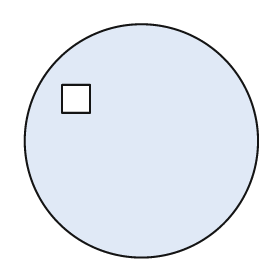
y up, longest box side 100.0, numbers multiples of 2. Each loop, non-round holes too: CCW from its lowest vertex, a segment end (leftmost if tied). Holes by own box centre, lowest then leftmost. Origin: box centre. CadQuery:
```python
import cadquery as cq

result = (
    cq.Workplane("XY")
    .moveTo(0.0, 0.0)
    .circle(50.0)
    .moveTo(-34.0, 12.0)
    .lineTo(-22.0, 12.0)
    .lineTo(-22.0, 24.0)
    .lineTo(-34.0, 24.0)
    .close()
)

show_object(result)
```